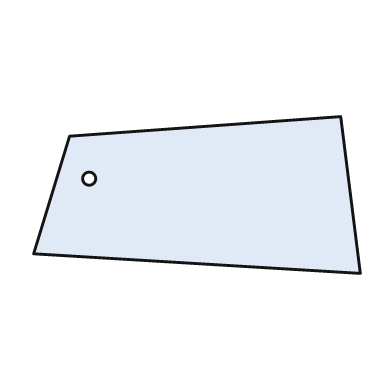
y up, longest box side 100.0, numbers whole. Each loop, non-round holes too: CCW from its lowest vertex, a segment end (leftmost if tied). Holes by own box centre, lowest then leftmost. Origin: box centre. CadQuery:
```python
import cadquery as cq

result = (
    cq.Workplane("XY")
    .moveTo(50.0, -24.0)
    .lineTo(44.0, 24.0)
    .lineTo(-39.0, 18.0)
    .lineTo(-50.0, -18.0)
    .close()
    .moveTo(-33.0, 5.0)
    .circle(2.0)
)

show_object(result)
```